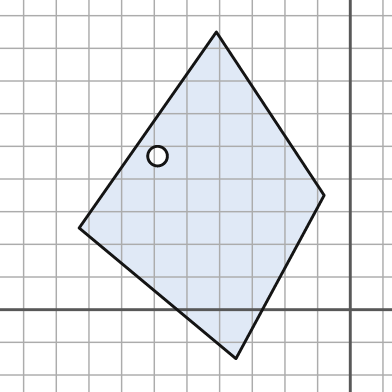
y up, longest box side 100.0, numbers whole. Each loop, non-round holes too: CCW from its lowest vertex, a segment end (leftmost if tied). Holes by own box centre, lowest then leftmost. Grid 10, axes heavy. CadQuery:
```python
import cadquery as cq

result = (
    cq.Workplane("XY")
    .moveTo(-35.0, -15.0)
    .lineTo(-8.0, 35.0)
    .lineTo(-41.0, 85.0)
    .lineTo(-83.0, 25.0)
    .close()
    .moveTo(-59.0, 47.0)
    .circle(3.0)
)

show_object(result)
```